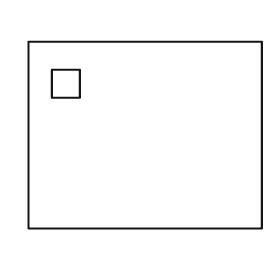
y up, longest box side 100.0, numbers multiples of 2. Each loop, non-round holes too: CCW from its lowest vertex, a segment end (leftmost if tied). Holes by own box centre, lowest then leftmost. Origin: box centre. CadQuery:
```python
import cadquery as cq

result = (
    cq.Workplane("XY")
    .moveTo(-50.0, -40.0)
    .lineTo(50.0, -40.0)
    .lineTo(50.0, 40.0)
    .lineTo(-50.0, 40.0)
    .close()
    .moveTo(-40.0, 16.0)
    .lineTo(-28.0, 16.0)
    .lineTo(-28.0, 28.0)
    .lineTo(-40.0, 28.0)
    .close()
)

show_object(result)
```